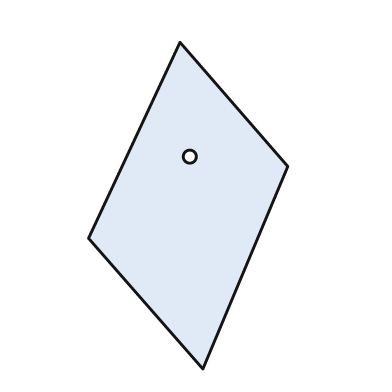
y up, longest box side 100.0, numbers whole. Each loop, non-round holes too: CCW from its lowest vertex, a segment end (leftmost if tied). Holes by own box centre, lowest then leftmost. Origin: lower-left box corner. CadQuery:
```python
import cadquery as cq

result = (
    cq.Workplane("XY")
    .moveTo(35.0, 0.0)
    .lineTo(61.0, 62.0)
    .lineTo(28.0, 100.0)
    .lineTo(0.0, 40.0)
    .close()
    .moveTo(31.0, 65.0)
    .circle(2.0)
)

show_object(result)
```